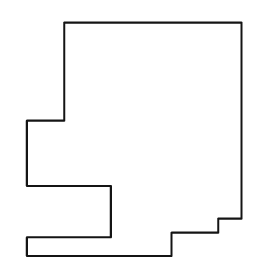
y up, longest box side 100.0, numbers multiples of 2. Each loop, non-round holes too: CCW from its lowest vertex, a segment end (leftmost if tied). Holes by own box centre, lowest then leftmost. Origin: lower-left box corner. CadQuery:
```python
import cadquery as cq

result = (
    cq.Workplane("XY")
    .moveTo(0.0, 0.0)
    .lineTo(62.0, 0.0)
    .lineTo(62.0, 10.0)
    .lineTo(82.0, 10.0)
    .lineTo(82.0, 16.0)
    .lineTo(92.0, 16.0)
    .lineTo(92.0, 100.0)
    .lineTo(16.0, 100.0)
    .lineTo(16.0, 58.0)
    .lineTo(0.0, 58.0)
    .lineTo(0.0, 30.0)
    .lineTo(36.0, 30.0)
    .lineTo(36.0, 8.0)
    .lineTo(0.0, 8.0)
    .close()
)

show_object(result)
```